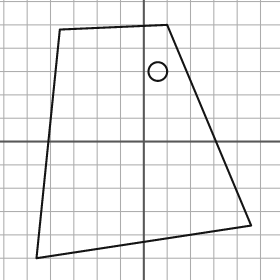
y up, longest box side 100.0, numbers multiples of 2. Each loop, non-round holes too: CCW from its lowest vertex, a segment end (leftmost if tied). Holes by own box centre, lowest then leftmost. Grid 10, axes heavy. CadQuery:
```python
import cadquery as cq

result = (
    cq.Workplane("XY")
    .moveTo(-46.0, -50.0)
    .lineTo(46.0, -36.0)
    .lineTo(10.0, 50.0)
    .lineTo(-36.0, 48.0)
    .close()
    .moveTo(6.0, 30.0)
    .circle(4.0)
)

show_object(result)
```